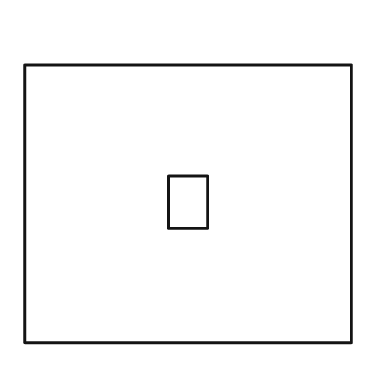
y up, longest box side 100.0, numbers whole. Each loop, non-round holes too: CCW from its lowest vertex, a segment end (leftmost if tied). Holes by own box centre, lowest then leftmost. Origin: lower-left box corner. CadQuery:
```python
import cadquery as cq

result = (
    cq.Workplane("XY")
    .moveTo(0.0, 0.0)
    .lineTo(100.0, 0.0)
    .lineTo(100.0, 85.0)
    .lineTo(0.0, 85.0)
    .close()
    .moveTo(44.0, 35.0)
    .lineTo(56.0, 35.0)
    .lineTo(56.0, 51.0)
    .lineTo(44.0, 51.0)
    .close()
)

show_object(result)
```